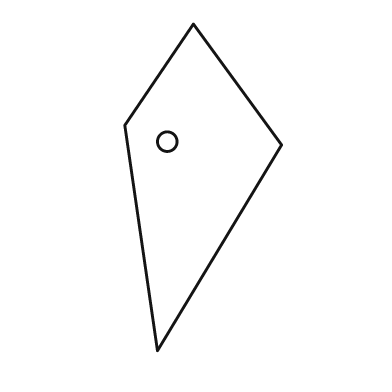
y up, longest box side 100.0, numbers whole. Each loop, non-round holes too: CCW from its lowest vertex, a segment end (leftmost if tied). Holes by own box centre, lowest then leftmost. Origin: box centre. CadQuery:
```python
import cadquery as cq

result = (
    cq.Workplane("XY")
    .moveTo(-14.0, -50.0)
    .lineTo(24.0, 13.0)
    .lineTo(-3.0, 50.0)
    .lineTo(-24.0, 19.0)
    .close()
    .moveTo(-11.0, 14.0)
    .circle(3.0)
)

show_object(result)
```